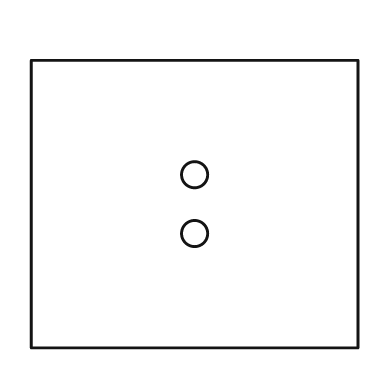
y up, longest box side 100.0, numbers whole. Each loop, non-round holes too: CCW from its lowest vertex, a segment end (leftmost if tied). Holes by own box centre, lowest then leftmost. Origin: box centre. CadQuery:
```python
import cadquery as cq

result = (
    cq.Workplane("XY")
    .moveTo(-50.0, -44.0)
    .lineTo(50.0, -44.0)
    .lineTo(50.0, 44.0)
    .lineTo(-50.0, 44.0)
    .close()
    .moveTo(0.0, -9.0)
    .circle(4.0)
    .moveTo(0.0, 9.0)
    .circle(4.0)
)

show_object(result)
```